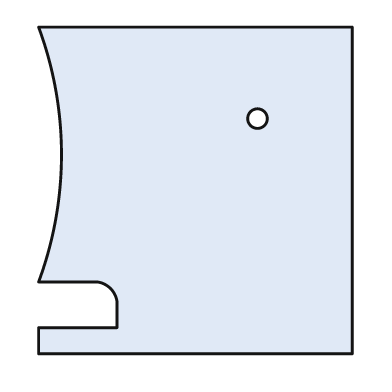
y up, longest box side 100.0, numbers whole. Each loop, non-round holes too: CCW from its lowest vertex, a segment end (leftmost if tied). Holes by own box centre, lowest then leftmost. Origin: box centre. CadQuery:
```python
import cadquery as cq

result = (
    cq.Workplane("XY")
    .moveTo(-48.0, -50.0)
    .lineTo(48.0, -50.0)
    .lineTo(48.0, 50.0)
    .lineTo(-48.0, 50.0)
    .threePointArc((-41.0, 11.0), (-48.0, -28.0))
    .lineTo(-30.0, -28.0)
    .threePointArc((-26.0, -30.0), (-24.0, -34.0))
    .lineTo(-24.0, -42.0)
    .lineTo(-48.0, -42.0)
    .close()
    .moveTo(19.0, 22.0)
    .circle(3.0)
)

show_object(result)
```